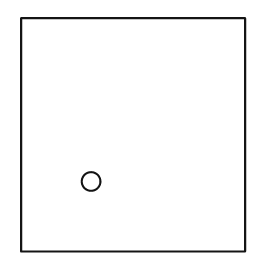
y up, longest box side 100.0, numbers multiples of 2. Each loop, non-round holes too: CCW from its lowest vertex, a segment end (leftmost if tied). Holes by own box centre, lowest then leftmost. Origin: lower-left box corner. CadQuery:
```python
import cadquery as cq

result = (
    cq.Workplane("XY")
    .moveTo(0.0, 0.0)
    .lineTo(96.0, 0.0)
    .lineTo(96.0, 100.0)
    .lineTo(0.0, 100.0)
    .close()
    .moveTo(30.0, 30.0)
    .circle(4.0)
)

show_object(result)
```